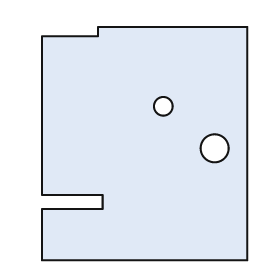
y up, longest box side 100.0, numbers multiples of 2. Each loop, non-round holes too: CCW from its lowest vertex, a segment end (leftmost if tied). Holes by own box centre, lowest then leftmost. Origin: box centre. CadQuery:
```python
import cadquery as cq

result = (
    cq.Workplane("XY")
    .moveTo(-44.0, -50.0)
    .lineTo(44.0, -50.0)
    .lineTo(44.0, 50.0)
    .lineTo(-20.0, 50.0)
    .lineTo(-20.0, 46.0)
    .lineTo(-44.0, 46.0)
    .lineTo(-44.0, -22.0)
    .lineTo(-18.0, -22.0)
    .lineTo(-18.0, -28.0)
    .lineTo(-44.0, -28.0)
    .close()
    .moveTo(30.0, -2.0)
    .circle(6.0)
    .moveTo(8.0, 16.0)
    .circle(4.0)
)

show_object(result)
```